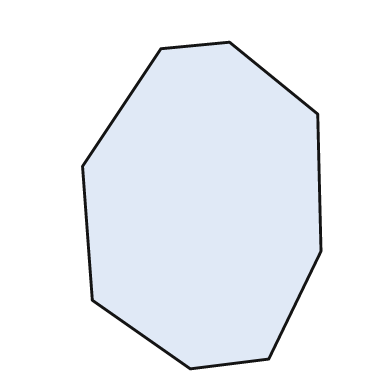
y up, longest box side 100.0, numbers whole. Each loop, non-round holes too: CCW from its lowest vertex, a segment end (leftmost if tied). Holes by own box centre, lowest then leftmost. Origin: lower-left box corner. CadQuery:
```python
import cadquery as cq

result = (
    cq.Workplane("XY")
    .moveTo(33.0, 0.0)
    .lineTo(57.0, 3.0)
    .lineTo(73.0, 36.0)
    .lineTo(72.0, 78.0)
    .lineTo(45.0, 100.0)
    .lineTo(24.0, 98.0)
    .lineTo(0.0, 62.0)
    .lineTo(3.0, 21.0)
    .close()
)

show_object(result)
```